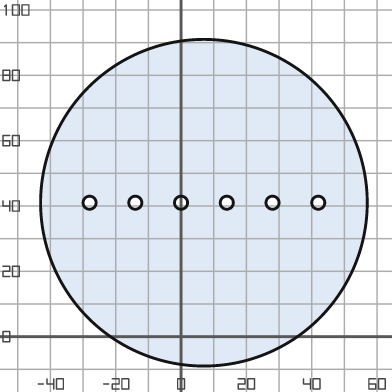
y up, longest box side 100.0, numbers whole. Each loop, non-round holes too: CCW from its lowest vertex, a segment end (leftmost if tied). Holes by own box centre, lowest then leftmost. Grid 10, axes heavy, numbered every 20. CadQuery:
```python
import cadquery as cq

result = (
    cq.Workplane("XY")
    .moveTo(7.0, 41.0)
    .circle(50.0)
    .moveTo(-28.0, 41.0)
    .circle(2.0)
    .moveTo(-14.0, 41.0)
    .circle(2.0)
    .moveTo(0.0, 41.0)
    .circle(2.0)
    .moveTo(14.0, 41.0)
    .circle(2.0)
    .moveTo(28.0, 41.0)
    .circle(2.0)
    .moveTo(42.0, 41.0)
    .circle(2.0)
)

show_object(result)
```